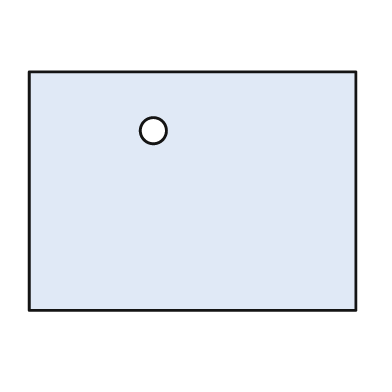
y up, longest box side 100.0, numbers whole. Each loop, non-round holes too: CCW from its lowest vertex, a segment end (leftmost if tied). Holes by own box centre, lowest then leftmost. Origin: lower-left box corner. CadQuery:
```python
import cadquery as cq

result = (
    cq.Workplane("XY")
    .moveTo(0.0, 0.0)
    .lineTo(100.0, 0.0)
    .lineTo(100.0, 73.0)
    .lineTo(0.0, 73.0)
    .close()
    .moveTo(38.0, 55.0)
    .circle(4.0)
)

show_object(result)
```